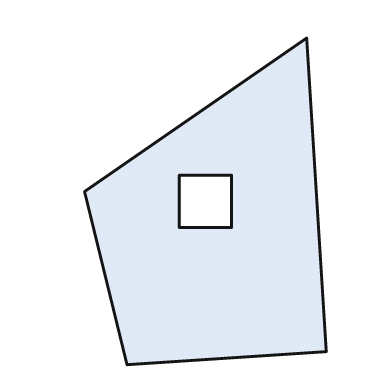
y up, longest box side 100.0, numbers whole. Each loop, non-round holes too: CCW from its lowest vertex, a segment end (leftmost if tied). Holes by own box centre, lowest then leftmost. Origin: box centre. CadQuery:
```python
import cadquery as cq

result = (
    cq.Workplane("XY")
    .moveTo(-24.0, -50.0)
    .lineTo(37.0, -46.0)
    .lineTo(31.0, 50.0)
    .lineTo(-37.0, 3.0)
    .close()
    .moveTo(-8.0, -8.0)
    .lineTo(8.0, -8.0)
    .lineTo(8.0, 8.0)
    .lineTo(-8.0, 8.0)
    .close()
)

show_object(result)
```